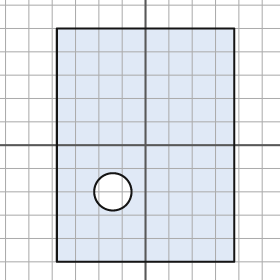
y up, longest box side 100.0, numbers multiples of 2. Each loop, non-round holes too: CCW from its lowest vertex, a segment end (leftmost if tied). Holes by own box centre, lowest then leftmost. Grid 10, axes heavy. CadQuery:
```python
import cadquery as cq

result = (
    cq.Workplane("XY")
    .moveTo(-38.0, -50.0)
    .lineTo(38.0, -50.0)
    .lineTo(38.0, 50.0)
    .lineTo(-38.0, 50.0)
    .close()
    .moveTo(-14.0, -20.0)
    .circle(8.0)
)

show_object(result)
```